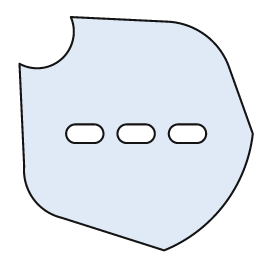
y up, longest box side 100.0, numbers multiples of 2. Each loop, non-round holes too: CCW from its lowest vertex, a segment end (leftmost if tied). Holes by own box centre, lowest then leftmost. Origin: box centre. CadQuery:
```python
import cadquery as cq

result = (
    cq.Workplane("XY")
    .moveTo(12.0, -50.0)
    .threePointArc((38.0, -30.0), (50.0, 0.0))
    .lineTo(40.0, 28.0)
    .threePointArc((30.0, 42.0), (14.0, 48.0))
    .lineTo(-28.0, 50.0)
    .threePointArc((-32.0, 32.0), (-50.0, 30.0))
    .lineTo(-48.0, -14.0)
    .threePointArc((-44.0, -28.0), (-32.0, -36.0))
    .close()
    .moveTo(-26.0, -4.0)
    .lineTo(-18.0, -4.0)
    .threePointArc((-14.0, 0.0), (-18.0, 4.0))
    .lineTo(-26.0, 4.0)
    .threePointArc((-30.0, 0.0), (-26.0, -4.0))
    .close()
    .moveTo(-4.0, -4.0)
    .lineTo(4.0, -4.0)
    .threePointArc((8.0, 0.0), (4.0, 4.0))
    .lineTo(-4.0, 4.0)
    .threePointArc((-8.0, 0.0), (-4.0, -4.0))
    .close()
    .moveTo(18.0, -4.0)
    .lineTo(26.0, -4.0)
    .threePointArc((30.0, 0.0), (26.0, 4.0))
    .lineTo(18.0, 4.0)
    .threePointArc((14.0, 0.0), (18.0, -4.0))
    .close()
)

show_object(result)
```